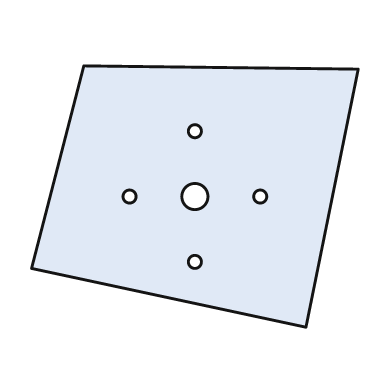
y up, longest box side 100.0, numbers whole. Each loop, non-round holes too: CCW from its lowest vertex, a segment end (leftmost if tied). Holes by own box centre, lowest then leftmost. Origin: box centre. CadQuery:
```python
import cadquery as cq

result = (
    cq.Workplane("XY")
    .moveTo(34.0, -40.0)
    .lineTo(50.0, 39.0)
    .lineTo(-34.0, 40.0)
    .lineTo(-50.0, -22.0)
    .close()
    .moveTo(0.0, -20.0)
    .circle(2.0)
    .moveTo(-20.0, 0.0)
    .circle(2.0)
    .moveTo(0.0, 0.0)
    .circle(4.0)
    .moveTo(20.0, 0.0)
    .circle(2.0)
    .moveTo(0.0, 20.0)
    .circle(2.0)
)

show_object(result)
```